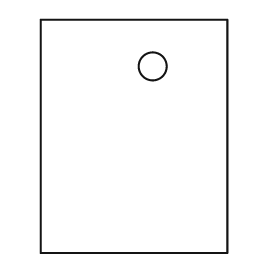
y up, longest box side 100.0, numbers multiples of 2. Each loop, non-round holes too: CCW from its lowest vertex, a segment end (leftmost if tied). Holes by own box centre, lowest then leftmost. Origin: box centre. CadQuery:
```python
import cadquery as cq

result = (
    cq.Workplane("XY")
    .moveTo(-40.0, -50.0)
    .lineTo(40.0, -50.0)
    .lineTo(40.0, 50.0)
    .lineTo(-40.0, 50.0)
    .close()
    .moveTo(8.0, 30.0)
    .circle(6.0)
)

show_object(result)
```